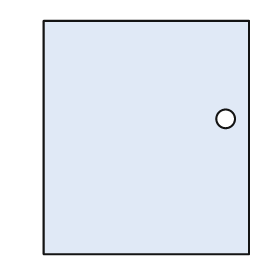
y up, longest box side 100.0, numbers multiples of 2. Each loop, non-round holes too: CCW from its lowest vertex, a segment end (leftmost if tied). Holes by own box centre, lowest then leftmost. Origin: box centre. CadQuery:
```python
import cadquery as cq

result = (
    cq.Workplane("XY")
    .moveTo(-44.0, -50.0)
    .lineTo(44.0, -50.0)
    .lineTo(44.0, 50.0)
    .lineTo(-44.0, 50.0)
    .close()
    .moveTo(34.0, 8.0)
    .circle(4.0)
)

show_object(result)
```